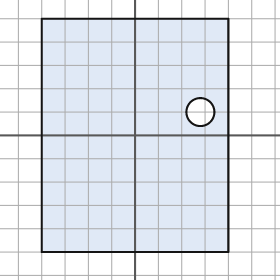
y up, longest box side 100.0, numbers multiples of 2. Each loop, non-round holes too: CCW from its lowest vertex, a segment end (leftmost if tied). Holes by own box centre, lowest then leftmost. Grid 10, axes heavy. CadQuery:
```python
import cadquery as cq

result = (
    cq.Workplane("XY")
    .moveTo(-40.0, -50.0)
    .lineTo(40.0, -50.0)
    .lineTo(40.0, 50.0)
    .lineTo(-40.0, 50.0)
    .close()
    .moveTo(28.0, 10.0)
    .circle(6.0)
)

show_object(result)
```